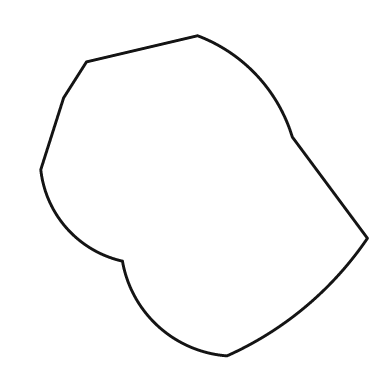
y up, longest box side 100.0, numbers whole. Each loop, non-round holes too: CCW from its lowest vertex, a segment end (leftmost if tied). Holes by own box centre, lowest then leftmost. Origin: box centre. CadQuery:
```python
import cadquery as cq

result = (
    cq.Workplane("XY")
    .moveTo(7.0, -49.0)
    .threePointArc((31.0, -34.0), (50.0, -13.0))
    .lineTo(27.0, 18.0)
    .threePointArc((16.0, 37.0), (-2.0, 49.0))
    .lineTo(-36.0, 41.0)
    .lineTo(-43.0, 30.0)
    .lineTo(-50.0, 8.0)
    .threePointArc((-42.0, -10.0), (-25.0, -20.0))
    .threePointArc((-14.0, -40.0), (7.0, -49.0))
    .close()
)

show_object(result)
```